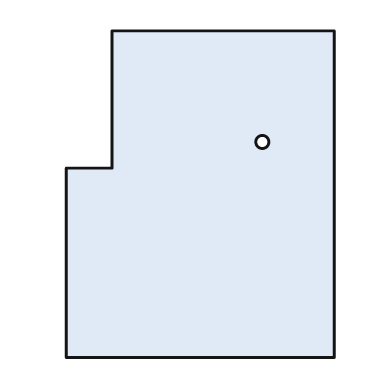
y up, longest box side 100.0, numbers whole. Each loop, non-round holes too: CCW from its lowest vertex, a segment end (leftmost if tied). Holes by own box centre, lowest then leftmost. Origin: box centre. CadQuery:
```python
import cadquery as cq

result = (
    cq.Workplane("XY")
    .moveTo(-41.0, -50.0)
    .lineTo(41.0, -50.0)
    .lineTo(41.0, 50.0)
    .lineTo(-27.0, 50.0)
    .lineTo(-27.0, 8.0)
    .lineTo(-41.0, 8.0)
    .close()
    .moveTo(19.0, 16.0)
    .circle(2.0)
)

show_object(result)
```